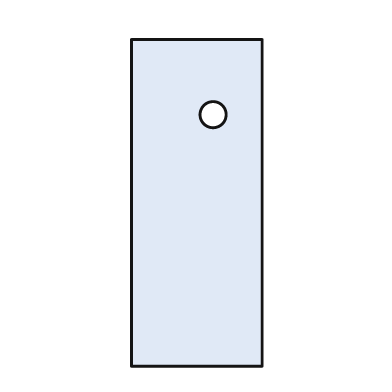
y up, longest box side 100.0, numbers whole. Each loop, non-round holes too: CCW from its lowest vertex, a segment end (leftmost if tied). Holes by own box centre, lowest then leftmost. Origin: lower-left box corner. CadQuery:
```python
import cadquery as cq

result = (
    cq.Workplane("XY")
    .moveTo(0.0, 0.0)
    .lineTo(40.0, 0.0)
    .lineTo(40.0, 100.0)
    .lineTo(0.0, 100.0)
    .close()
    .moveTo(25.0, 77.0)
    .circle(4.0)
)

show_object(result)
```